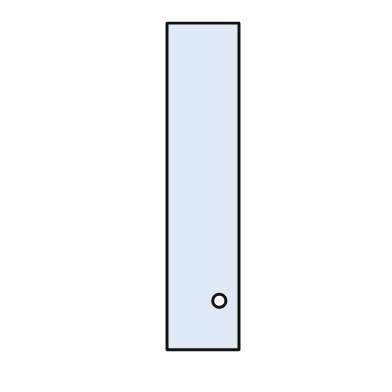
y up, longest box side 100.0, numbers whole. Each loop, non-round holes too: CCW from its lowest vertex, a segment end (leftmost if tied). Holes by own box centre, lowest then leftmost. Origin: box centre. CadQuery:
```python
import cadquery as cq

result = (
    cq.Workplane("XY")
    .moveTo(-11.0, -50.0)
    .lineTo(11.0, -50.0)
    .lineTo(11.0, 50.0)
    .lineTo(-11.0, 50.0)
    .close()
    .moveTo(5.0, -35.0)
    .circle(2.0)
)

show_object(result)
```